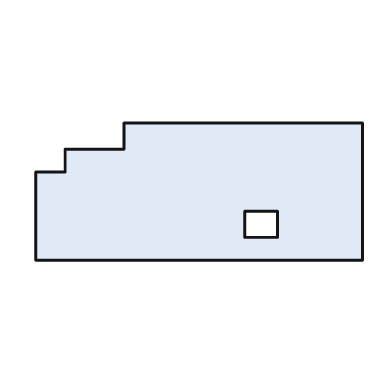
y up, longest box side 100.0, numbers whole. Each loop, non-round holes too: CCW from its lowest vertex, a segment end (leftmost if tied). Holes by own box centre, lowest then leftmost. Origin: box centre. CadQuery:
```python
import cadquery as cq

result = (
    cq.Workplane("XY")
    .moveTo(-50.0, -21.0)
    .lineTo(50.0, -21.0)
    .lineTo(50.0, 21.0)
    .lineTo(-23.0, 21.0)
    .lineTo(-23.0, 13.0)
    .lineTo(-41.0, 13.0)
    .lineTo(-41.0, 6.0)
    .lineTo(-50.0, 6.0)
    .close()
    .moveTo(14.0, -14.0)
    .lineTo(24.0, -14.0)
    .lineTo(24.0, -6.0)
    .lineTo(14.0, -6.0)
    .close()
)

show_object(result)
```